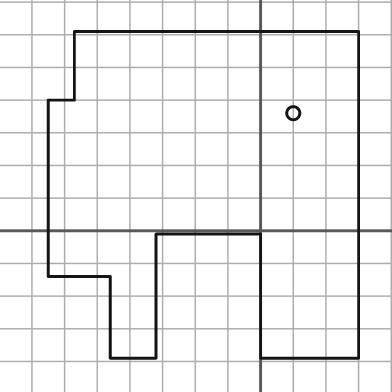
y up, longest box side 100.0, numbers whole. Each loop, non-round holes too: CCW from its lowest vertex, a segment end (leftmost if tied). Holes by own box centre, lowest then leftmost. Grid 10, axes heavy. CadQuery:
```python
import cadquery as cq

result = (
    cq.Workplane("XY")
    .moveTo(-46.0, -39.0)
    .lineTo(-32.0, -39.0)
    .lineTo(-32.0, -1.0)
    .lineTo(0.0, -1.0)
    .lineTo(0.0, -39.0)
    .lineTo(30.0, -39.0)
    .lineTo(30.0, 61.0)
    .lineTo(-57.0, 61.0)
    .lineTo(-57.0, 40.0)
    .lineTo(-65.0, 40.0)
    .lineTo(-65.0, -14.0)
    .lineTo(-46.0, -14.0)
    .close()
    .moveTo(10.0, 36.0)
    .circle(2.0)
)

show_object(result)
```